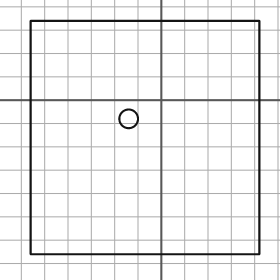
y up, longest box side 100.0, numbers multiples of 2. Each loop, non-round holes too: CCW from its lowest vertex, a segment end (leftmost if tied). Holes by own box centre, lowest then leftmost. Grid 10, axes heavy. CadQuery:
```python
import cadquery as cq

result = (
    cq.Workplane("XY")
    .moveTo(-56.0, -66.0)
    .lineTo(42.0, -66.0)
    .lineTo(42.0, 34.0)
    .lineTo(-56.0, 34.0)
    .close()
    .moveTo(-14.0, -8.0)
    .circle(4.0)
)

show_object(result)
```